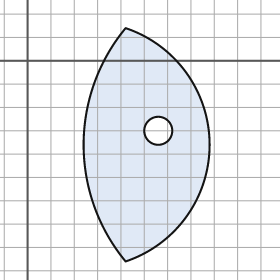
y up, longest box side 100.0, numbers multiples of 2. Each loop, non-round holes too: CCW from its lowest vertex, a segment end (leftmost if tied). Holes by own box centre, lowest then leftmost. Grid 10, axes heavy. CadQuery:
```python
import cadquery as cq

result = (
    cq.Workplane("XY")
    .moveTo(42.0, -86.0)
    .threePointArc((78.0, -36.0), (42.0, 14.0))
    .threePointArc((24.0, -36.0), (42.0, -86.0))
    .close()
    .moveTo(56.0, -30.0)
    .circle(6.0)
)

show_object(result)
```